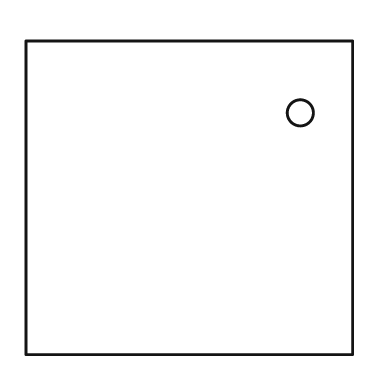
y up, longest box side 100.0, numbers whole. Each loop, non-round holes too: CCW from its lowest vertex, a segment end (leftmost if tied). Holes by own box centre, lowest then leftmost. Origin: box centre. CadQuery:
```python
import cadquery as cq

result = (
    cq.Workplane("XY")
    .moveTo(-50.0, -48.0)
    .lineTo(50.0, -48.0)
    .lineTo(50.0, 48.0)
    .lineTo(-50.0, 48.0)
    .close()
    .moveTo(34.0, 26.0)
    .circle(4.0)
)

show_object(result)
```